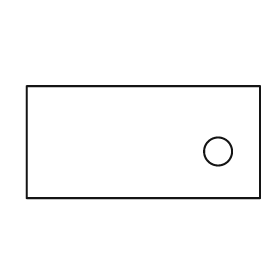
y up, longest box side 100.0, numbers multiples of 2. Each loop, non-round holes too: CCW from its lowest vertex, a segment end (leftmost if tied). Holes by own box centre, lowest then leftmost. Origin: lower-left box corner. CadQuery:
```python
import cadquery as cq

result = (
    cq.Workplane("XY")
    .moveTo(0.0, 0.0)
    .lineTo(100.0, 0.0)
    .lineTo(100.0, 48.0)
    .lineTo(0.0, 48.0)
    .close()
    .moveTo(82.0, 20.0)
    .circle(6.0)
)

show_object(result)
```